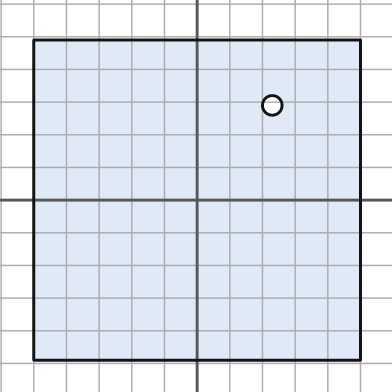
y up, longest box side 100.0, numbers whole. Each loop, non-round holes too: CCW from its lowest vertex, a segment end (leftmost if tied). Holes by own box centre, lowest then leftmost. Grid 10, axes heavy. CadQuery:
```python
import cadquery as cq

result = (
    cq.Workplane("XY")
    .moveTo(-50.0, -49.0)
    .lineTo(50.0, -49.0)
    .lineTo(50.0, 49.0)
    .lineTo(-50.0, 49.0)
    .close()
    .moveTo(23.0, 29.0)
    .circle(3.0)
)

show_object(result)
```